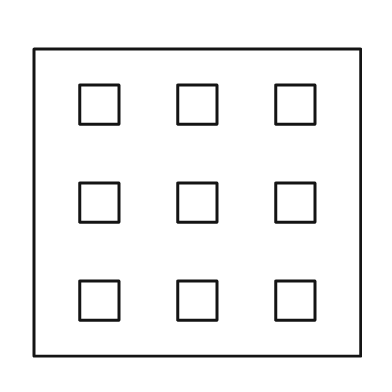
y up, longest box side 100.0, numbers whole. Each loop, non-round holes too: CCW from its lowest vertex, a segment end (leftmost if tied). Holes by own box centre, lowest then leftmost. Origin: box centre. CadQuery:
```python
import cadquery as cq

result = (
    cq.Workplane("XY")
    .moveTo(-50.0, -47.0)
    .lineTo(50.0, -47.0)
    .lineTo(50.0, 47.0)
    .lineTo(-50.0, 47.0)
    .close()
    .moveTo(-36.0, -36.0)
    .lineTo(-24.0, -36.0)
    .lineTo(-24.0, -24.0)
    .lineTo(-36.0, -24.0)
    .close()
    .moveTo(-6.0, -36.0)
    .lineTo(6.0, -36.0)
    .lineTo(6.0, -24.0)
    .lineTo(-6.0, -24.0)
    .close()
    .moveTo(24.0, -36.0)
    .lineTo(36.0, -36.0)
    .lineTo(36.0, -24.0)
    .lineTo(24.0, -24.0)
    .close()
    .moveTo(-36.0, -6.0)
    .lineTo(-24.0, -6.0)
    .lineTo(-24.0, 6.0)
    .lineTo(-36.0, 6.0)
    .close()
    .moveTo(-6.0, -6.0)
    .lineTo(6.0, -6.0)
    .lineTo(6.0, 6.0)
    .lineTo(-6.0, 6.0)
    .close()
    .moveTo(24.0, -6.0)
    .lineTo(36.0, -6.0)
    .lineTo(36.0, 6.0)
    .lineTo(24.0, 6.0)
    .close()
    .moveTo(-36.0, 24.0)
    .lineTo(-24.0, 24.0)
    .lineTo(-24.0, 36.0)
    .lineTo(-36.0, 36.0)
    .close()
    .moveTo(-6.0, 24.0)
    .lineTo(6.0, 24.0)
    .lineTo(6.0, 36.0)
    .lineTo(-6.0, 36.0)
    .close()
    .moveTo(24.0, 24.0)
    .lineTo(36.0, 24.0)
    .lineTo(36.0, 36.0)
    .lineTo(24.0, 36.0)
    .close()
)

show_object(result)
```